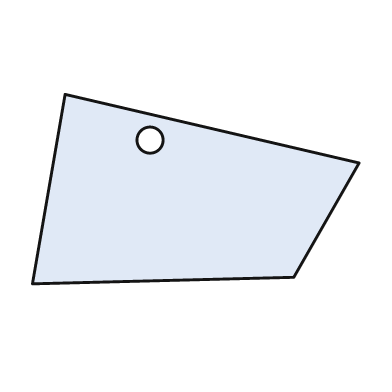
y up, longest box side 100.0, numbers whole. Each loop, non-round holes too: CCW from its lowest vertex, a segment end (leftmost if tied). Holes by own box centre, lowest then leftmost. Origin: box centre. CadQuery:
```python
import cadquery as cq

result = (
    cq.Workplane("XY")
    .moveTo(-50.0, -29.0)
    .lineTo(30.0, -27.0)
    .lineTo(50.0, 8.0)
    .lineTo(-40.0, 29.0)
    .close()
    .moveTo(-14.0, 15.0)
    .circle(4.0)
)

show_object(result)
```